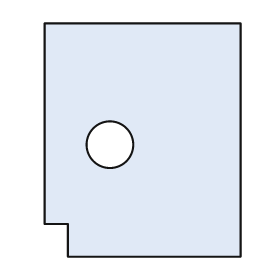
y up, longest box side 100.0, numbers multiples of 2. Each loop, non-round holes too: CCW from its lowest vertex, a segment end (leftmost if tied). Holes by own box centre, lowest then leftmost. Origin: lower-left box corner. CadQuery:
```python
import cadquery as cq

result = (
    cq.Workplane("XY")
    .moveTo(10.0, 0.0)
    .lineTo(84.0, 0.0)
    .lineTo(84.0, 100.0)
    .lineTo(0.0, 100.0)
    .lineTo(0.0, 14.0)
    .lineTo(10.0, 14.0)
    .close()
    .moveTo(28.0, 48.0)
    .circle(10.0)
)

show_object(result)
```